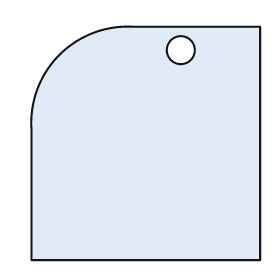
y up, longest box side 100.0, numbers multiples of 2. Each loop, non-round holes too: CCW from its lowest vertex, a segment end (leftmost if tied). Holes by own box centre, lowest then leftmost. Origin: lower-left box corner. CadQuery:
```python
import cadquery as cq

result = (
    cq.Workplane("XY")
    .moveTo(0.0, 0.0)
    .lineTo(98.0, 0.0)
    .lineTo(98.0, 100.0)
    .lineTo(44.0, 100.0)
    .threePointArc((12.0, 88.0), (0.0, 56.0))
    .close()
    .moveTo(64.0, 90.0)
    .circle(6.0)
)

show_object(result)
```